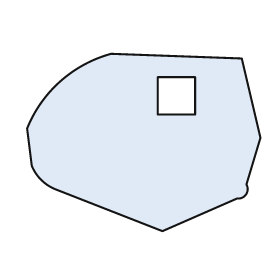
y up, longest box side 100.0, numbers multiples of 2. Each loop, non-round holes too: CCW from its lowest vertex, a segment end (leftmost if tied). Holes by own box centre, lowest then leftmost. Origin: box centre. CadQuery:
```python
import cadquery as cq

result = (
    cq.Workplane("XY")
    .moveTo(8.0, -38.0)
    .lineTo(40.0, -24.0)
    .threePointArc((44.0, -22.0), (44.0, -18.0))
    .lineTo(50.0, 2.0)
    .lineTo(42.0, 36.0)
    .lineTo(-14.0, 38.0)
    .threePointArc((-36.0, 26.0), (-50.0, 6.0))
    .lineTo(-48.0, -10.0)
    .threePointArc((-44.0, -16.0), (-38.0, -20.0))
    .close()
    .moveTo(6.0, 12.0)
    .lineTo(22.0, 12.0)
    .lineTo(22.0, 28.0)
    .lineTo(6.0, 28.0)
    .close()
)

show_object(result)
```